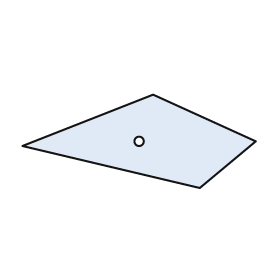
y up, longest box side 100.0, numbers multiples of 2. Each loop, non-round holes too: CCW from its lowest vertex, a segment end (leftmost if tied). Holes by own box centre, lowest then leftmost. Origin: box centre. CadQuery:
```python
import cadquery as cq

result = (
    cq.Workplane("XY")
    .moveTo(26.0, -20.0)
    .lineTo(50.0, 0.0)
    .lineTo(6.0, 20.0)
    .lineTo(-50.0, -2.0)
    .close()
    .moveTo(0.0, 0.0)
    .circle(2.0)
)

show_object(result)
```